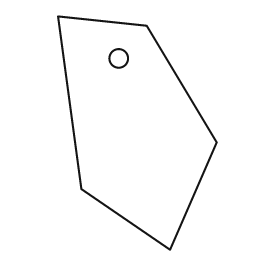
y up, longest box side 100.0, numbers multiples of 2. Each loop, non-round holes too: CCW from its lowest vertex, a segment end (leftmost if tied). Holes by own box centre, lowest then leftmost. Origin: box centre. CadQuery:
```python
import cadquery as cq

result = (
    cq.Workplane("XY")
    .moveTo(14.0, -50.0)
    .lineTo(34.0, -4.0)
    .lineTo(4.0, 46.0)
    .lineTo(-34.0, 50.0)
    .lineTo(-24.0, -24.0)
    .close()
    .moveTo(-8.0, 32.0)
    .circle(4.0)
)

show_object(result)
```